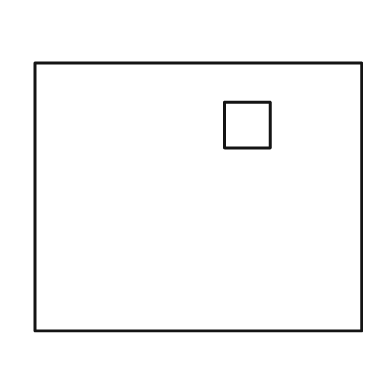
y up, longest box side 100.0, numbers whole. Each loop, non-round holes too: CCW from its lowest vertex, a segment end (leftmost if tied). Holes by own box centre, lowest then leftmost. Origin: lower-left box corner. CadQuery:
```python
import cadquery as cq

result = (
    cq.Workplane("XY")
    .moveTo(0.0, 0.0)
    .lineTo(100.0, 0.0)
    .lineTo(100.0, 82.0)
    .lineTo(0.0, 82.0)
    .close()
    .moveTo(58.0, 56.0)
    .lineTo(72.0, 56.0)
    .lineTo(72.0, 70.0)
    .lineTo(58.0, 70.0)
    .close()
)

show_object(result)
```